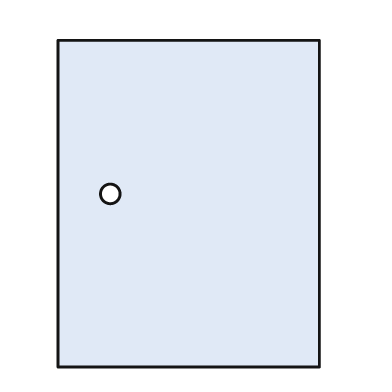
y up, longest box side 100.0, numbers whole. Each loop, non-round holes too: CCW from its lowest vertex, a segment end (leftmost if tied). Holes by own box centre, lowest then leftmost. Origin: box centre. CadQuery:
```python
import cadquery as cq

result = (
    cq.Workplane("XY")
    .moveTo(-40.0, -50.0)
    .lineTo(40.0, -50.0)
    .lineTo(40.0, 50.0)
    .lineTo(-40.0, 50.0)
    .close()
    .moveTo(-24.0, 3.0)
    .circle(3.0)
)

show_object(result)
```